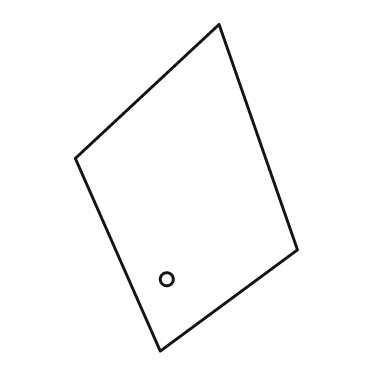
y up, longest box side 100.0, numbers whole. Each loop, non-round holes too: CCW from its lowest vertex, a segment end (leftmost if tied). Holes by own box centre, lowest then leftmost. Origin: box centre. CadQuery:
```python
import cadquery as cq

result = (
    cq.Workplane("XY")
    .moveTo(-8.0, -50.0)
    .lineTo(34.0, -19.0)
    .lineTo(10.0, 50.0)
    .lineTo(-34.0, 9.0)
    .close()
    .moveTo(-6.0, -28.0)
    .circle(2.0)
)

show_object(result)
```